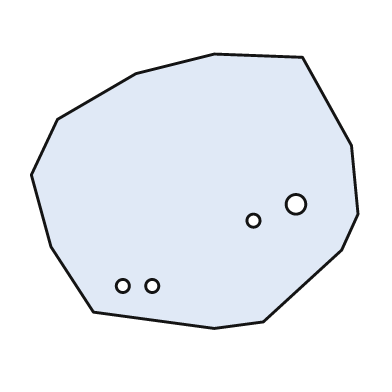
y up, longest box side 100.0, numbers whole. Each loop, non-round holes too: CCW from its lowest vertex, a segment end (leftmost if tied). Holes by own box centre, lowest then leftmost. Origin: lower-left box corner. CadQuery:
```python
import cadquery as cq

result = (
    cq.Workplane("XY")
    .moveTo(56.0, 0.0)
    .lineTo(71.0, 2.0)
    .lineTo(95.0, 24.0)
    .lineTo(100.0, 35.0)
    .lineTo(98.0, 56.0)
    .lineTo(83.0, 83.0)
    .lineTo(56.0, 84.0)
    .lineTo(32.0, 78.0)
    .lineTo(8.0, 64.0)
    .lineTo(0.0, 47.0)
    .lineTo(6.0, 25.0)
    .lineTo(19.0, 5.0)
    .close()
    .moveTo(28.0, 13.0)
    .circle(2.0)
    .moveTo(37.0, 13.0)
    .circle(2.0)
    .moveTo(68.0, 33.0)
    .circle(2.0)
    .moveTo(81.0, 38.0)
    .circle(3.0)
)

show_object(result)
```